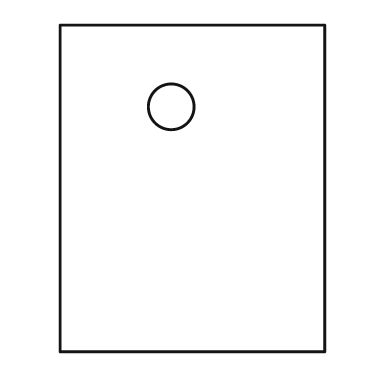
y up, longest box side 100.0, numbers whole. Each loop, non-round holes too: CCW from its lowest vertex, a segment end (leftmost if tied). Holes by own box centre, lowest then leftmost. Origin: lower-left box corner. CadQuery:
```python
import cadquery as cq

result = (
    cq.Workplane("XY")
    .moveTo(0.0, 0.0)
    .lineTo(81.0, 0.0)
    .lineTo(81.0, 100.0)
    .lineTo(0.0, 100.0)
    .close()
    .moveTo(34.0, 75.0)
    .circle(7.0)
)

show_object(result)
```